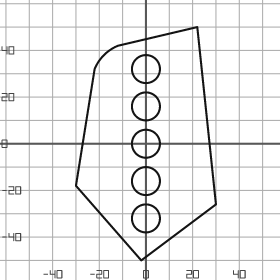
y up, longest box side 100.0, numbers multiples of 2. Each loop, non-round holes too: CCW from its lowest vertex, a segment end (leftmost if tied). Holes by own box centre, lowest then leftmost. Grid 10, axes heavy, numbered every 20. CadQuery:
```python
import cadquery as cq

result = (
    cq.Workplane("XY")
    .moveTo(-2.0, -50.0)
    .lineTo(30.0, -26.0)
    .lineTo(22.0, 50.0)
    .lineTo(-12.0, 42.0)
    .threePointArc((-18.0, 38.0), (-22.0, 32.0))
    .lineTo(-30.0, -18.0)
    .close()
    .moveTo(0.0, -32.0)
    .circle(6.0)
    .moveTo(0.0, -16.0)
    .circle(6.0)
    .moveTo(0.0, 0.0)
    .circle(6.0)
    .moveTo(0.0, 16.0)
    .circle(6.0)
    .moveTo(0.0, 32.0)
    .circle(6.0)
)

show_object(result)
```